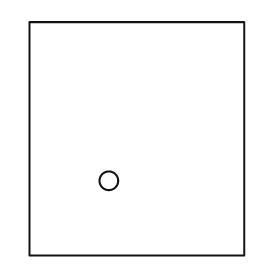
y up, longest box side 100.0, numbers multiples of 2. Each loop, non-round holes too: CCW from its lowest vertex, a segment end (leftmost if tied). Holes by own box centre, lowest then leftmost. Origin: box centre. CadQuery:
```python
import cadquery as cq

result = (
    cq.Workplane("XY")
    .moveTo(-46.0, -50.0)
    .lineTo(46.0, -50.0)
    .lineTo(46.0, 50.0)
    .lineTo(-46.0, 50.0)
    .close()
    .moveTo(-12.0, -18.0)
    .circle(4.0)
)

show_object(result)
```